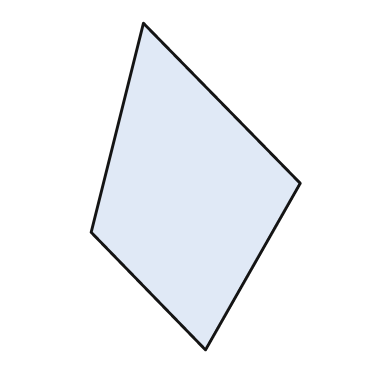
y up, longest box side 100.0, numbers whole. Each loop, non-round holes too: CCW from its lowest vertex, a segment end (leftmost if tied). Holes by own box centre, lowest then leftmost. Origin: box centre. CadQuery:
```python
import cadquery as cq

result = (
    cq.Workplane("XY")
    .moveTo(3.0, -50.0)
    .lineTo(32.0, 1.0)
    .lineTo(-16.0, 50.0)
    .lineTo(-32.0, -14.0)
    .close()
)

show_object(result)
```